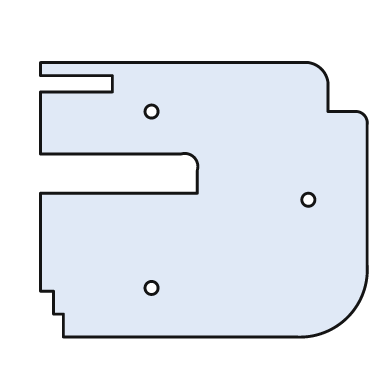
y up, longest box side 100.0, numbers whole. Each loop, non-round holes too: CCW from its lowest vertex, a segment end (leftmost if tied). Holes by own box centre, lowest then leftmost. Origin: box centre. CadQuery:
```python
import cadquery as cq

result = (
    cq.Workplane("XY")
    .moveTo(-43.0, -42.0)
    .lineTo(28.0, -42.0)
    .threePointArc((44.0, -36.0), (50.0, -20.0))
    .lineTo(50.0, 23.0)
    .threePointArc((49.0, 26.0), (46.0, 27.0))
    .lineTo(38.0, 27.0)
    .lineTo(38.0, 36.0)
    .threePointArc((36.0, 40.0), (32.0, 42.0))
    .lineTo(-50.0, 42.0)
    .lineTo(-50.0, 38.0)
    .lineTo(-28.0, 38.0)
    .lineTo(-28.0, 33.0)
    .lineTo(-50.0, 33.0)
    .lineTo(-50.0, 14.0)
    .lineTo(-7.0, 14.0)
    .threePointArc((-3.0, 13.0), (-2.0, 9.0))
    .lineTo(-2.0, 2.0)
    .lineTo(-50.0, 2.0)
    .lineTo(-50.0, -28.0)
    .lineTo(-46.0, -28.0)
    .lineTo(-46.0, -35.0)
    .lineTo(-43.0, -35.0)
    .close()
    .moveTo(-16.0, -27.0)
    .circle(2.0)
    .moveTo(32.0, 0.0)
    .circle(2.0)
    .moveTo(-16.0, 27.0)
    .circle(2.0)
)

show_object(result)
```